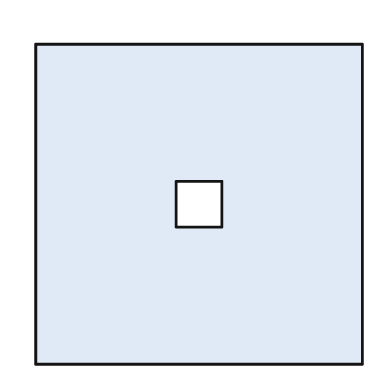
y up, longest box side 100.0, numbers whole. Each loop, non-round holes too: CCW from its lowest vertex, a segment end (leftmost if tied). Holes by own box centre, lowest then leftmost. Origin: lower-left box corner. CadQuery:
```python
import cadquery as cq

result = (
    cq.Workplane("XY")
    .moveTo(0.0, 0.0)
    .lineTo(100.0, 0.0)
    .lineTo(100.0, 98.0)
    .lineTo(0.0, 98.0)
    .close()
    .moveTo(43.0, 42.0)
    .lineTo(57.0, 42.0)
    .lineTo(57.0, 56.0)
    .lineTo(43.0, 56.0)
    .close()
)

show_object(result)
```